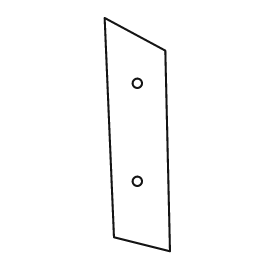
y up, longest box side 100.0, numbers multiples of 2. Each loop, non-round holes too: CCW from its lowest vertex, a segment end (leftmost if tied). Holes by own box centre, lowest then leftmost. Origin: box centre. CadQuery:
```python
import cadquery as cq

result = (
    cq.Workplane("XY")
    .moveTo(14.0, -50.0)
    .lineTo(12.0, 36.0)
    .lineTo(-14.0, 50.0)
    .lineTo(-10.0, -44.0)
    .close()
    .moveTo(0.0, -20.0)
    .circle(2.0)
    .moveTo(0.0, 22.0)
    .circle(2.0)
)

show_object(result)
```